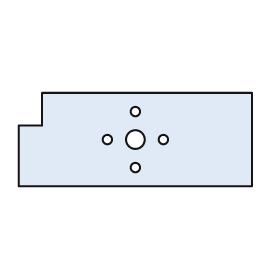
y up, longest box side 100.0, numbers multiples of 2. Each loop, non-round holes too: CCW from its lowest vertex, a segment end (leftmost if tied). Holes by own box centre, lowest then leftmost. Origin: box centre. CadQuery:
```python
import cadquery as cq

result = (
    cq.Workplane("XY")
    .moveTo(-50.0, -20.0)
    .lineTo(50.0, -20.0)
    .lineTo(50.0, 20.0)
    .lineTo(-40.0, 20.0)
    .lineTo(-40.0, 6.0)
    .lineTo(-50.0, 6.0)
    .close()
    .moveTo(0.0, -12.0)
    .circle(2.0)
    .moveTo(-12.0, 0.0)
    .circle(2.0)
    .moveTo(0.0, 0.0)
    .circle(4.0)
    .moveTo(12.0, 0.0)
    .circle(2.0)
    .moveTo(0.0, 12.0)
    .circle(2.0)
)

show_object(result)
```